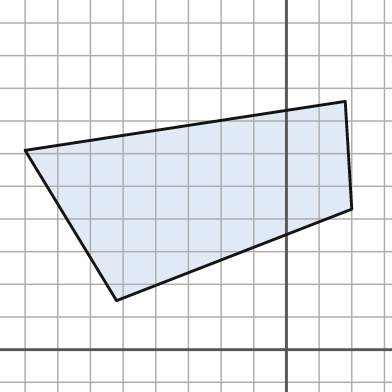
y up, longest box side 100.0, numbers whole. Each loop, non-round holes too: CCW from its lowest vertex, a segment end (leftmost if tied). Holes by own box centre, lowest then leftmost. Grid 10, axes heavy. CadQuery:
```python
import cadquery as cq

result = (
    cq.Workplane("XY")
    .moveTo(-52.0, 15.0)
    .lineTo(20.0, 43.0)
    .lineTo(18.0, 76.0)
    .lineTo(-80.0, 61.0)
    .close()
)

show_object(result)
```